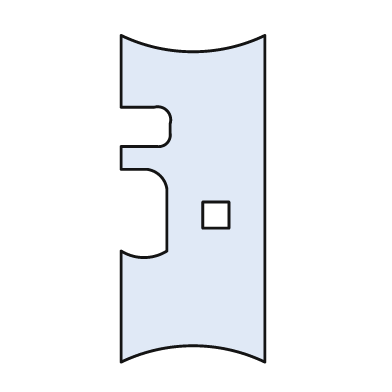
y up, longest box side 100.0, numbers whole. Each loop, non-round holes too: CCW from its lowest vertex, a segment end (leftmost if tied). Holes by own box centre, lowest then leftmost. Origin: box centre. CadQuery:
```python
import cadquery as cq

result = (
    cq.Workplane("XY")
    .moveTo(-22.0, -50.0)
    .threePointArc((0.0, -45.0), (22.0, -50.0))
    .lineTo(22.0, 50.0)
    .threePointArc((0.0, 45.0), (-22.0, 50.0))
    .lineTo(-22.0, 28.0)
    .lineTo(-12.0, 28.0)
    .threePointArc((-8.0, 27.0), (-7.0, 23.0))
    .lineTo(-7.0, 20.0)
    .threePointArc((-8.0, 17.0), (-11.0, 16.0))
    .lineTo(-22.0, 16.0)
    .lineTo(-22.0, 9.0)
    .lineTo(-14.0, 9.0)
    .threePointArc((-10.0, 7.0), (-8.0, 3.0))
    .lineTo(-8.0, -16.0)
    .threePointArc((-15.0, -18.0), (-22.0, -16.0))
    .close()
    .moveTo(3.0, -9.0)
    .lineTo(11.0, -9.0)
    .lineTo(11.0, -1.0)
    .lineTo(3.0, -1.0)
    .close()
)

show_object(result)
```